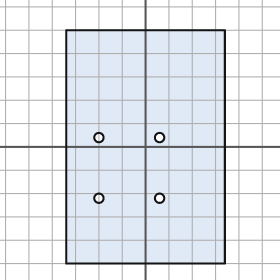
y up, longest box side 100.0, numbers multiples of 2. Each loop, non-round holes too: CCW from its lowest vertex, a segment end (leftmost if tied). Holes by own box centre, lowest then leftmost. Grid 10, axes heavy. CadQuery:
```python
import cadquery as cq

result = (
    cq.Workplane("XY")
    .moveTo(-34.0, -50.0)
    .lineTo(34.0, -50.0)
    .lineTo(34.0, 50.0)
    .lineTo(-34.0, 50.0)
    .close()
    .moveTo(-20.0, -22.0)
    .circle(2.0)
    .moveTo(6.0, -22.0)
    .circle(2.0)
    .moveTo(-20.0, 4.0)
    .circle(2.0)
    .moveTo(6.0, 4.0)
    .circle(2.0)
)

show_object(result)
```